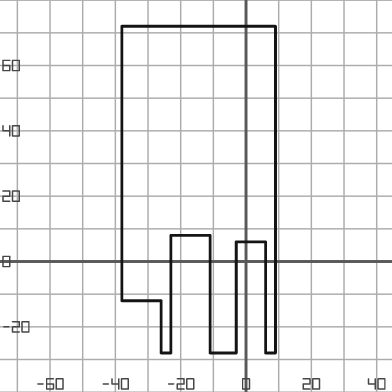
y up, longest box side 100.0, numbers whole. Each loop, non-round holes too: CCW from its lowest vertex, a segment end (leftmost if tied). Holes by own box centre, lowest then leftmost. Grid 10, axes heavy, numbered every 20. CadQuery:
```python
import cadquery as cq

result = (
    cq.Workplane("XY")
    .moveTo(-26.0, -28.0)
    .lineTo(-23.0, -28.0)
    .lineTo(-23.0, 8.0)
    .lineTo(-11.0, 8.0)
    .lineTo(-11.0, -28.0)
    .lineTo(-3.0, -28.0)
    .lineTo(-3.0, 6.0)
    .lineTo(6.0, 6.0)
    .lineTo(6.0, -28.0)
    .lineTo(9.0, -28.0)
    .lineTo(9.0, 72.0)
    .lineTo(-38.0, 72.0)
    .lineTo(-38.0, -12.0)
    .lineTo(-26.0, -12.0)
    .close()
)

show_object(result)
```